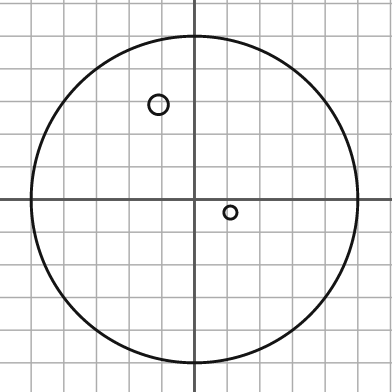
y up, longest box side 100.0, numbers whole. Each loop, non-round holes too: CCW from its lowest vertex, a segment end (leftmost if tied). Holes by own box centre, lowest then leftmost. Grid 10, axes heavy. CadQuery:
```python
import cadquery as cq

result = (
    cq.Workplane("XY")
    .moveTo(0.0, 0.0)
    .circle(50.0)
    .moveTo(11.0, -4.0)
    .circle(2.0)
    .moveTo(-11.0, 29.0)
    .circle(3.0)
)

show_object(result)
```